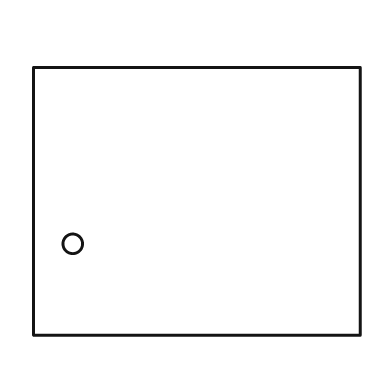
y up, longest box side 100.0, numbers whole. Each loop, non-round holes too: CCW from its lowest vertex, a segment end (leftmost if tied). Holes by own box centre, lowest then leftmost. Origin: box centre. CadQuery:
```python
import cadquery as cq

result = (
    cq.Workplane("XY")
    .moveTo(-50.0, -41.0)
    .lineTo(50.0, -41.0)
    .lineTo(50.0, 41.0)
    .lineTo(-50.0, 41.0)
    .close()
    .moveTo(-38.0, -13.0)
    .circle(3.0)
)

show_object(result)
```